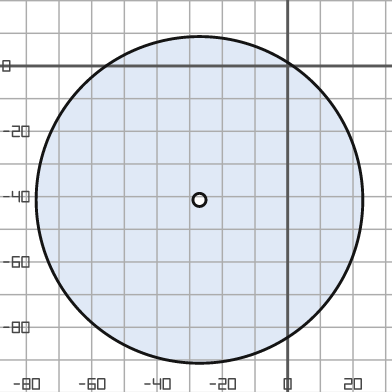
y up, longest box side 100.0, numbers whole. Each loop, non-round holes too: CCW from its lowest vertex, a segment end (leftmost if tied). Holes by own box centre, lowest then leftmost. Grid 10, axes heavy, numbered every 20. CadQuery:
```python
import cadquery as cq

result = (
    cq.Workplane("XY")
    .moveTo(-27.0, -41.0)
    .circle(50.0)
    .moveTo(-27.0, -41.0)
    .circle(2.0)
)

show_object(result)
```